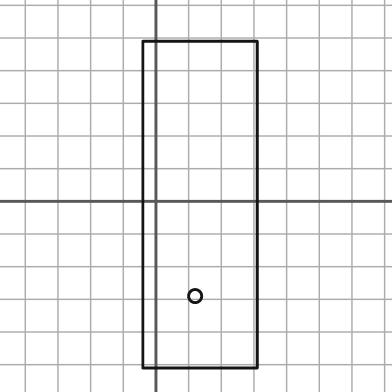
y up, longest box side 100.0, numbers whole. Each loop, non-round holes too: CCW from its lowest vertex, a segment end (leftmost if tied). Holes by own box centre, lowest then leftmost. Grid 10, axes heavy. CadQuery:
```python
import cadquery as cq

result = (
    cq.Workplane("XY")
    .moveTo(-4.0, -51.0)
    .lineTo(31.0, -51.0)
    .lineTo(31.0, 49.0)
    .lineTo(-4.0, 49.0)
    .close()
    .moveTo(12.0, -29.0)
    .circle(2.0)
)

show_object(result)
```